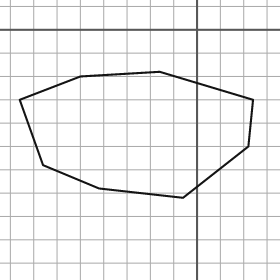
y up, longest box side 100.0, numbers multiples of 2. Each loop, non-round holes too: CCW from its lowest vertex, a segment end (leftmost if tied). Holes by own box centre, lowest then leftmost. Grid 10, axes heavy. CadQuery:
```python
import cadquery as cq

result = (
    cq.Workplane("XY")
    .moveTo(-6.0, -72.0)
    .lineTo(22.0, -50.0)
    .lineTo(24.0, -30.0)
    .lineTo(-16.0, -18.0)
    .lineTo(-50.0, -20.0)
    .lineTo(-76.0, -30.0)
    .lineTo(-66.0, -58.0)
    .lineTo(-42.0, -68.0)
    .close()
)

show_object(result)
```